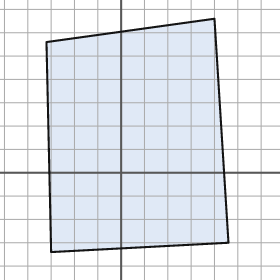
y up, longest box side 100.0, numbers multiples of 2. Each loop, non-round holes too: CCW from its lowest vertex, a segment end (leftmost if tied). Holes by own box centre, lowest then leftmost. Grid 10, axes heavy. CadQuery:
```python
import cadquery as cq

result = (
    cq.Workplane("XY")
    .moveTo(-30.0, -34.0)
    .lineTo(46.0, -30.0)
    .lineTo(40.0, 66.0)
    .lineTo(-32.0, 56.0)
    .close()
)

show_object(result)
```